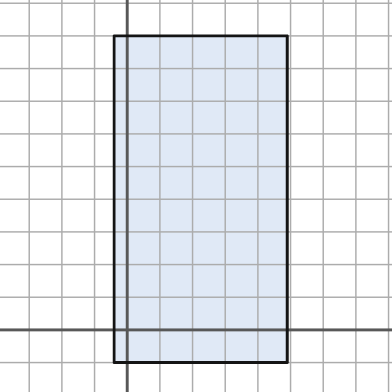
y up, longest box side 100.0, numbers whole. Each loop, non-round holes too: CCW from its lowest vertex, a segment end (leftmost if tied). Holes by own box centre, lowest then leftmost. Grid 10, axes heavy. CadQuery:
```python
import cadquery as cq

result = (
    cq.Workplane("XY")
    .moveTo(-4.0, -10.0)
    .lineTo(49.0, -10.0)
    .lineTo(49.0, 90.0)
    .lineTo(-4.0, 90.0)
    .close()
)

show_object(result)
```